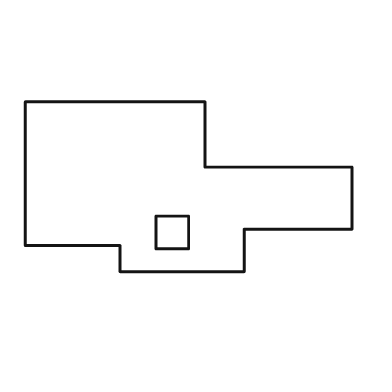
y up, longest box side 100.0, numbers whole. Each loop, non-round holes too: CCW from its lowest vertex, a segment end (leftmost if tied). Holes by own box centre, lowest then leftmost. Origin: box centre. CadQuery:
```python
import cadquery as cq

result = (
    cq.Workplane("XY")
    .moveTo(-21.0, -26.0)
    .lineTo(17.0, -26.0)
    .lineTo(17.0, -13.0)
    .lineTo(50.0, -13.0)
    .lineTo(50.0, 6.0)
    .lineTo(5.0, 6.0)
    .lineTo(5.0, 26.0)
    .lineTo(-50.0, 26.0)
    .lineTo(-50.0, -18.0)
    .lineTo(-21.0, -18.0)
    .close()
    .moveTo(-10.0, -19.0)
    .lineTo(0.0, -19.0)
    .lineTo(0.0, -9.0)
    .lineTo(-10.0, -9.0)
    .close()
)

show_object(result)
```